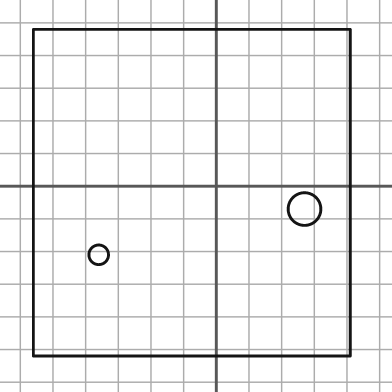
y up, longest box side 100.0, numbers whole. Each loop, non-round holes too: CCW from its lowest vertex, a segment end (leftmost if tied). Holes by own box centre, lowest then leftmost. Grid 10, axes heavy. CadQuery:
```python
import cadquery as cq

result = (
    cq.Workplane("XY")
    .moveTo(-56.0, -52.0)
    .lineTo(41.0, -52.0)
    .lineTo(41.0, 48.0)
    .lineTo(-56.0, 48.0)
    .close()
    .moveTo(-36.0, -21.0)
    .circle(3.0)
    .moveTo(27.0, -7.0)
    .circle(5.0)
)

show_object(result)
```